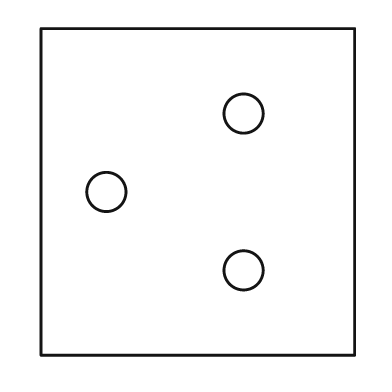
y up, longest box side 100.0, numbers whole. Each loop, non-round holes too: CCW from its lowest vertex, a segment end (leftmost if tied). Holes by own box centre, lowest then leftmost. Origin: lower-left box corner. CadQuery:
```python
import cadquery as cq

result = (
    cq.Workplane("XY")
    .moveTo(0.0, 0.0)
    .lineTo(96.0, 0.0)
    .lineTo(96.0, 100.0)
    .lineTo(0.0, 100.0)
    .close()
    .moveTo(62.0, 26.0)
    .circle(6.0)
    .moveTo(20.0, 50.0)
    .circle(6.0)
    .moveTo(62.0, 74.0)
    .circle(6.0)
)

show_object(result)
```